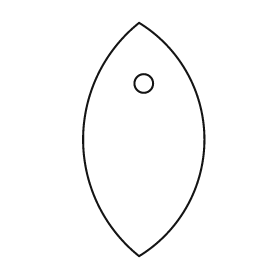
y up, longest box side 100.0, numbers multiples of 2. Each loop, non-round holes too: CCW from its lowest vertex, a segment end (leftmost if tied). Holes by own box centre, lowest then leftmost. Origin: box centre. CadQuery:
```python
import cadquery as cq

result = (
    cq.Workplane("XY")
    .moveTo(-2.0, -50.0)
    .threePointArc((26.0, 0.0), (-2.0, 50.0))
    .threePointArc((-26.0, 0.0), (-2.0, -50.0))
    .close()
    .moveTo(0.0, 24.0)
    .circle(4.0)
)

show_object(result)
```